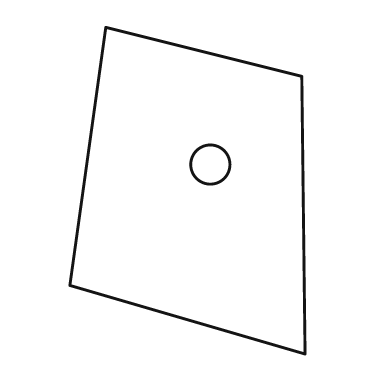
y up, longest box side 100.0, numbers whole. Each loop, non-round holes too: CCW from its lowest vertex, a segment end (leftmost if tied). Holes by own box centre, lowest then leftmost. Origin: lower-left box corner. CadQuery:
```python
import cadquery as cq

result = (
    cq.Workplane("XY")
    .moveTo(72.0, 0.0)
    .lineTo(71.0, 85.0)
    .lineTo(11.0, 100.0)
    .lineTo(0.0, 21.0)
    .close()
    .moveTo(43.0, 58.0)
    .circle(6.0)
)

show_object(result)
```